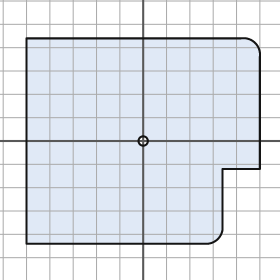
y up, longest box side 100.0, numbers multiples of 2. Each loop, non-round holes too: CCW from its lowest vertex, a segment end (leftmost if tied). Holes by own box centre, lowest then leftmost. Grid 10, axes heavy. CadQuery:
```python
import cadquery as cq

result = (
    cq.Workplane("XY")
    .moveTo(-50.0, -44.0)
    .lineTo(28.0, -44.0)
    .threePointArc((32.0, -42.0), (34.0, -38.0))
    .lineTo(34.0, -12.0)
    .lineTo(50.0, -12.0)
    .lineTo(50.0, 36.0)
    .threePointArc((48.0, 42.0), (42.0, 44.0))
    .lineTo(-50.0, 44.0)
    .close()
    .moveTo(0.0, 0.0)
    .circle(2.0)
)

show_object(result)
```